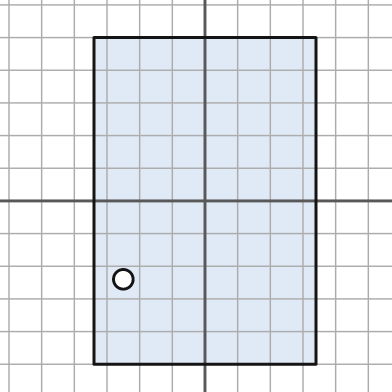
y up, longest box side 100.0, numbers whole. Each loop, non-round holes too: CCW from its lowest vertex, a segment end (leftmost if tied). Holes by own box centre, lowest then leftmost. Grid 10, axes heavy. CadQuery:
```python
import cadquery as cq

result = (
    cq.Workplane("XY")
    .moveTo(-34.0, -50.0)
    .lineTo(34.0, -50.0)
    .lineTo(34.0, 50.0)
    .lineTo(-34.0, 50.0)
    .close()
    .moveTo(-25.0, -24.0)
    .circle(3.0)
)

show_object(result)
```